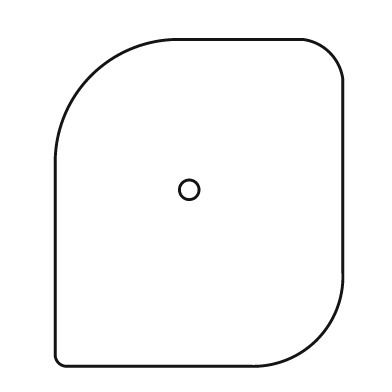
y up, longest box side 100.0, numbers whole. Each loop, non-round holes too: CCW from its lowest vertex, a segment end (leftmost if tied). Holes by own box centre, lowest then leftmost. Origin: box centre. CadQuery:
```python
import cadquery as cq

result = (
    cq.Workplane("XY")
    .moveTo(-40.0, -50.0)
    .lineTo(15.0, -50.0)
    .threePointArc((36.0, -42.0), (44.0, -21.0))
    .lineTo(44.0, 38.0)
    .threePointArc((40.0, 46.0), (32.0, 50.0))
    .lineTo(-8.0, 50.0)
    .threePointArc((-33.0, 39.0), (-44.0, 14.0))
    .lineTo(-44.0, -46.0)
    .threePointArc((-43.0, -49.0), (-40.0, -50.0))
    .close()
    .moveTo(-3.0, 4.0)
    .circle(3.0)
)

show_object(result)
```